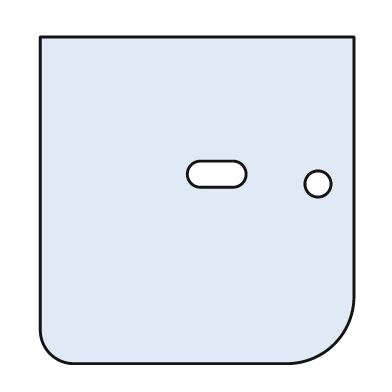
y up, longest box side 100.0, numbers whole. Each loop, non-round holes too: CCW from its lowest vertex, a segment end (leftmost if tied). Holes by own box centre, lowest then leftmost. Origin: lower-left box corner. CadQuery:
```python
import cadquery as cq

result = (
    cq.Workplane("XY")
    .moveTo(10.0, 0.0)
    .lineTo(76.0, 0.0)
    .threePointArc((90.0, 6.0), (96.0, 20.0))
    .lineTo(96.0, 100.0)
    .lineTo(0.0, 100.0)
    .lineTo(0.0, 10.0)
    .threePointArc((3.0, 3.0), (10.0, 0.0))
    .close()
    .moveTo(85.0, 55.0)
    .circle(4.0)
    .moveTo(49.0, 54.0)
    .lineTo(59.0, 54.0)
    .threePointArc((63.0, 58.0), (59.0, 62.0))
    .lineTo(49.0, 62.0)
    .threePointArc((45.0, 58.0), (49.0, 54.0))
    .close()
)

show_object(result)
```